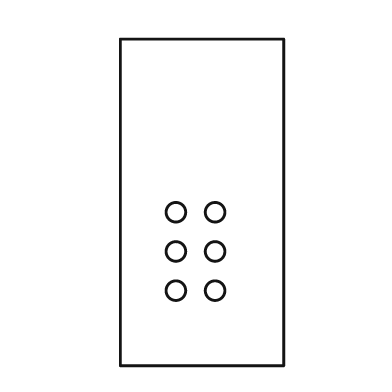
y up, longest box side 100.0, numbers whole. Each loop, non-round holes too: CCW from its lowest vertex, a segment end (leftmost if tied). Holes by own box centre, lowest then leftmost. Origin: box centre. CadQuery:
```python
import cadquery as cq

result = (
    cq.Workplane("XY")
    .moveTo(-25.0, -50.0)
    .lineTo(25.0, -50.0)
    .lineTo(25.0, 50.0)
    .lineTo(-25.0, 50.0)
    .close()
    .moveTo(-8.0, -27.0)
    .circle(3.0)
    .moveTo(4.0, -27.0)
    .circle(3.0)
    .moveTo(-8.0, -15.0)
    .circle(3.0)
    .moveTo(4.0, -15.0)
    .circle(3.0)
    .moveTo(-8.0, -3.0)
    .circle(3.0)
    .moveTo(4.0, -3.0)
    .circle(3.0)
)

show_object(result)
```